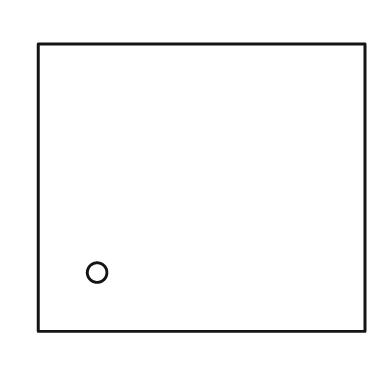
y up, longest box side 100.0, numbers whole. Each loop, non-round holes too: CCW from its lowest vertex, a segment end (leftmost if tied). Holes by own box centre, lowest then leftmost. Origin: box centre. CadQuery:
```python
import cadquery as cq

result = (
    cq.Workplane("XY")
    .moveTo(-50.0, -44.0)
    .lineTo(50.0, -44.0)
    .lineTo(50.0, 44.0)
    .lineTo(-50.0, 44.0)
    .close()
    .moveTo(-32.0, -26.0)
    .circle(3.0)
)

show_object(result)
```